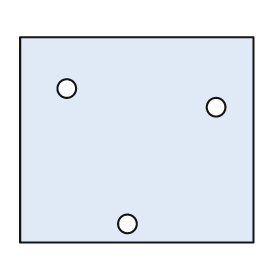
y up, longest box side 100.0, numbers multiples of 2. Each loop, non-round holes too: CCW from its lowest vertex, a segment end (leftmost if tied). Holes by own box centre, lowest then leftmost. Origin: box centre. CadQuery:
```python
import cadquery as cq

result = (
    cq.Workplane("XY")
    .moveTo(-50.0, -44.0)
    .lineTo(50.0, -44.0)
    .lineTo(50.0, 44.0)
    .lineTo(-50.0, 44.0)
    .close()
    .moveTo(-4.0, -36.0)
    .circle(4.0)
    .moveTo(34.0, 14.0)
    .circle(4.0)
    .moveTo(-30.0, 22.0)
    .circle(4.0)
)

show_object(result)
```